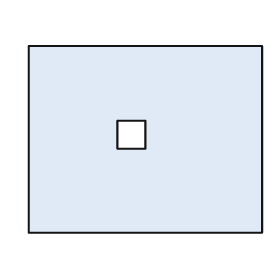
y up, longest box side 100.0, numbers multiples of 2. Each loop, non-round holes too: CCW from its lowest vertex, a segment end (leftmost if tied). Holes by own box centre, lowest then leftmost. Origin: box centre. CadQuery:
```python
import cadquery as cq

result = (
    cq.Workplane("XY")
    .moveTo(-50.0, -40.0)
    .lineTo(50.0, -40.0)
    .lineTo(50.0, 40.0)
    .lineTo(-50.0, 40.0)
    .close()
    .moveTo(-12.0, -4.0)
    .lineTo(0.0, -4.0)
    .lineTo(0.0, 8.0)
    .lineTo(-12.0, 8.0)
    .close()
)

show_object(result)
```